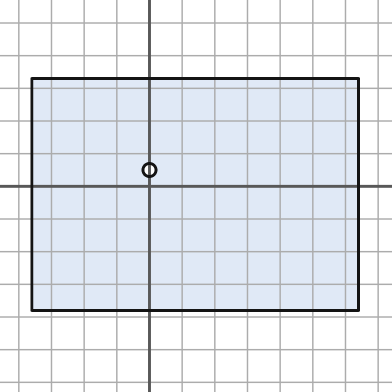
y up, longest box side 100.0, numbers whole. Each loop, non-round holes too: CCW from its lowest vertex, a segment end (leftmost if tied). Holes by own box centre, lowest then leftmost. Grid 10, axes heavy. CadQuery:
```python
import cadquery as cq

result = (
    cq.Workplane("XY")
    .moveTo(-36.0, -38.0)
    .lineTo(64.0, -38.0)
    .lineTo(64.0, 33.0)
    .lineTo(-36.0, 33.0)
    .close()
    .moveTo(0.0, 5.0)
    .circle(2.0)
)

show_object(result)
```